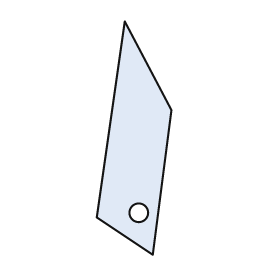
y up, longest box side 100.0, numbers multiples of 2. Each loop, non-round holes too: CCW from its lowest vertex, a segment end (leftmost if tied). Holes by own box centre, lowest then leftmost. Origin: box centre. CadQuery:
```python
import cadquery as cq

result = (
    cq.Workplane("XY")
    .moveTo(8.0, -50.0)
    .lineTo(16.0, 12.0)
    .lineTo(-4.0, 50.0)
    .lineTo(-16.0, -34.0)
    .close()
    .moveTo(2.0, -32.0)
    .circle(4.0)
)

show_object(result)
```